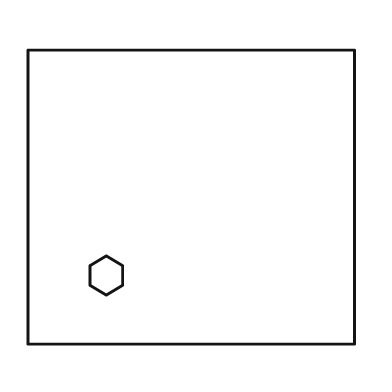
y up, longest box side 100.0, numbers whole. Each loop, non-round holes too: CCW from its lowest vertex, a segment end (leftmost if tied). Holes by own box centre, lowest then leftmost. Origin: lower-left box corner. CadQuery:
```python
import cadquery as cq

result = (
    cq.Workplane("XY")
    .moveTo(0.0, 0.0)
    .lineTo(100.0, 0.0)
    .lineTo(100.0, 90.0)
    .lineTo(0.0, 90.0)
    .close()
    .moveTo(24.0, 15.0)
    .lineTo(29.0, 18.0)
    .lineTo(29.0, 24.0)
    .lineTo(24.0, 27.0)
    .lineTo(19.0, 24.0)
    .lineTo(19.0, 18.0)
    .close()
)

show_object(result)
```